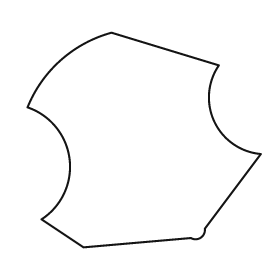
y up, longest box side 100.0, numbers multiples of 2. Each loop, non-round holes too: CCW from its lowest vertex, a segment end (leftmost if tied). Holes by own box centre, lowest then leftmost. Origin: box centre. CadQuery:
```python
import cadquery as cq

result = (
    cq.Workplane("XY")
    .moveTo(-26.0, -46.0)
    .lineTo(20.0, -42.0)
    .threePointArc((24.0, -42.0), (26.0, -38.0))
    .lineTo(50.0, -6.0)
    .threePointArc((30.0, 8.0), (32.0, 32.0))
    .lineTo(-14.0, 46.0)
    .threePointArc((-36.0, 34.0), (-50.0, 14.0))
    .threePointArc((-32.0, -8.0), (-44.0, -34.0))
    .close()
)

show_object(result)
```